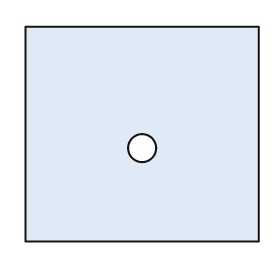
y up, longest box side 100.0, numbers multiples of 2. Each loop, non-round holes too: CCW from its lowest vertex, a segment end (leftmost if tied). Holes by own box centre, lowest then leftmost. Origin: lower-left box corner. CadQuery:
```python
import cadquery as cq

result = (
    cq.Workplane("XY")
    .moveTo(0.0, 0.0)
    .lineTo(100.0, 0.0)
    .lineTo(100.0, 92.0)
    .lineTo(0.0, 92.0)
    .close()
    .moveTo(50.0, 40.0)
    .circle(6.0)
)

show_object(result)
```